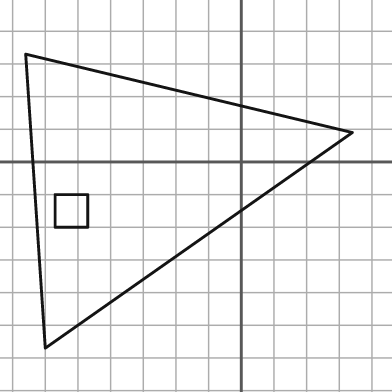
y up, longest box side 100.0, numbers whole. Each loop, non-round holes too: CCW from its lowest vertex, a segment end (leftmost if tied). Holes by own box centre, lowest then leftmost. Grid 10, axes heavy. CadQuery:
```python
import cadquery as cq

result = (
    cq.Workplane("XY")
    .moveTo(-60.0, -57.0)
    .lineTo(34.0, 9.0)
    .lineTo(-66.0, 33.0)
    .close()
    .moveTo(-57.0, -20.0)
    .lineTo(-47.0, -20.0)
    .lineTo(-47.0, -10.0)
    .lineTo(-57.0, -10.0)
    .close()
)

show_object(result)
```